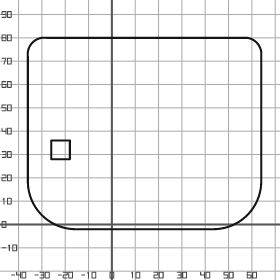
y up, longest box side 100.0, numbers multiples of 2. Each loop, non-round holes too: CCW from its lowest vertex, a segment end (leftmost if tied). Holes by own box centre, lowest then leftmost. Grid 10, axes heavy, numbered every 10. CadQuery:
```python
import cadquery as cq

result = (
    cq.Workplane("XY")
    .moveTo(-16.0, -2.0)
    .lineTo(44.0, -2.0)
    .threePointArc((58.0, 4.0), (64.0, 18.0))
    .lineTo(64.0, 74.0)
    .threePointArc((62.0, 78.0), (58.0, 80.0))
    .lineTo(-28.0, 80.0)
    .threePointArc((-34.0, 78.0), (-36.0, 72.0))
    .lineTo(-36.0, 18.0)
    .threePointArc((-30.0, 4.0), (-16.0, -2.0))
    .close()
    .moveTo(-26.0, 28.0)
    .lineTo(-18.0, 28.0)
    .lineTo(-18.0, 36.0)
    .lineTo(-26.0, 36.0)
    .close()
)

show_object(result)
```